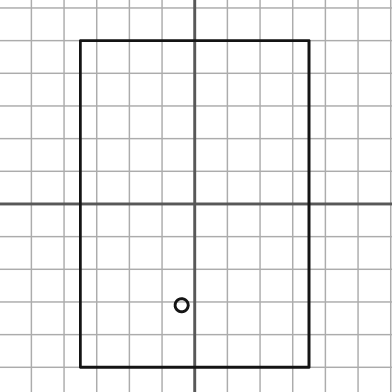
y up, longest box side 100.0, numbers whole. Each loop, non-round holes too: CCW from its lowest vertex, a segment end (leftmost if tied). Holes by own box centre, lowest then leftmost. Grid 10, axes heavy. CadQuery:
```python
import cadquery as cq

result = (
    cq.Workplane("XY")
    .moveTo(-35.0, -50.0)
    .lineTo(35.0, -50.0)
    .lineTo(35.0, 50.0)
    .lineTo(-35.0, 50.0)
    .close()
    .moveTo(-4.0, -31.0)
    .circle(2.0)
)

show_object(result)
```